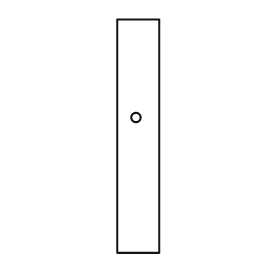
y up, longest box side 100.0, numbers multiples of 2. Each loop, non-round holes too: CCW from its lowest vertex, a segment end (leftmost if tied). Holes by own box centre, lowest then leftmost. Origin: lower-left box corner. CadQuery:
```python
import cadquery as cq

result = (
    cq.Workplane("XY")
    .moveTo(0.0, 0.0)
    .lineTo(18.0, 0.0)
    .lineTo(18.0, 100.0)
    .lineTo(0.0, 100.0)
    .close()
    .moveTo(8.0, 58.0)
    .circle(2.0)
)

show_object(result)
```